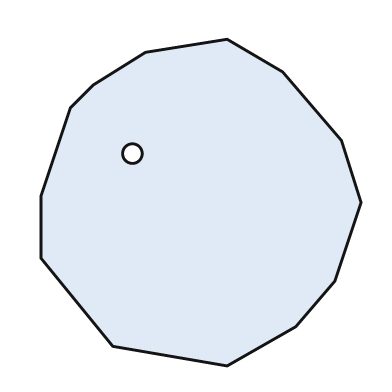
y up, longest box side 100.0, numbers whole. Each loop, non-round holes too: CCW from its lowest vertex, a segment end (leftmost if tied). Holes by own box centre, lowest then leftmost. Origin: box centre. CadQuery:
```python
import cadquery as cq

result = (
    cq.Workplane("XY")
    .moveTo(8.0, -50.0)
    .lineTo(29.0, -38.0)
    .lineTo(41.0, -24.0)
    .lineTo(49.0, 0.0)
    .lineTo(43.0, 19.0)
    .lineTo(25.0, 40.0)
    .lineTo(8.0, 50.0)
    .lineTo(-17.0, 46.0)
    .lineTo(-33.0, 36.0)
    .lineTo(-40.0, 29.0)
    .lineTo(-49.0, 2.0)
    .lineTo(-49.0, -17.0)
    .lineTo(-27.0, -44.0)
    .close()
    .moveTo(-21.0, 15.0)
    .circle(3.0)
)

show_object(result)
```